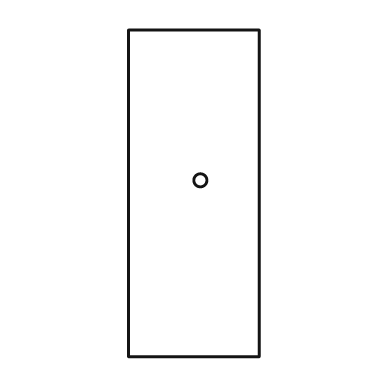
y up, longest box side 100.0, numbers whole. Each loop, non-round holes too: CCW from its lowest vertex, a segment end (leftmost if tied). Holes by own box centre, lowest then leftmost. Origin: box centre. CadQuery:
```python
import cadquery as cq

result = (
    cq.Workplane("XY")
    .moveTo(-20.0, -50.0)
    .lineTo(20.0, -50.0)
    .lineTo(20.0, 50.0)
    .lineTo(-20.0, 50.0)
    .close()
    .moveTo(2.0, 4.0)
    .circle(2.0)
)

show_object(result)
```